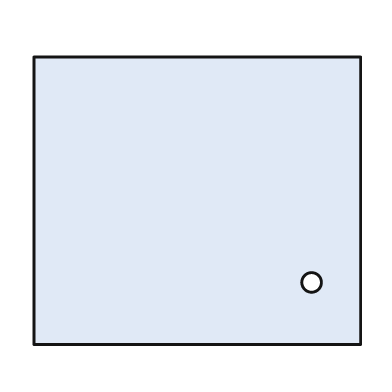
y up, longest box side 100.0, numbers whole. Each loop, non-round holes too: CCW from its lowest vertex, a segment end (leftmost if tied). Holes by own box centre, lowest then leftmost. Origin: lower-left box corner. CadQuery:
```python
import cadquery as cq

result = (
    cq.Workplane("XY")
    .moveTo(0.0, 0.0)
    .lineTo(100.0, 0.0)
    .lineTo(100.0, 88.0)
    .lineTo(0.0, 88.0)
    .close()
    .moveTo(85.0, 19.0)
    .circle(3.0)
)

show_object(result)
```